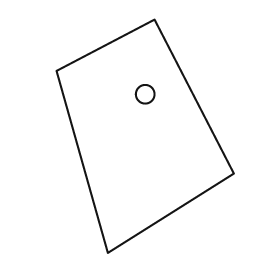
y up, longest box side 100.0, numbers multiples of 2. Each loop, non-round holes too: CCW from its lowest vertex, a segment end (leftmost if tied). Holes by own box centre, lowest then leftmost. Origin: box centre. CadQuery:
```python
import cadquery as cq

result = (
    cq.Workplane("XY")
    .moveTo(-16.0, -50.0)
    .lineTo(38.0, -16.0)
    .lineTo(4.0, 50.0)
    .lineTo(-38.0, 28.0)
    .close()
    .moveTo(0.0, 18.0)
    .circle(4.0)
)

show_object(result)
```